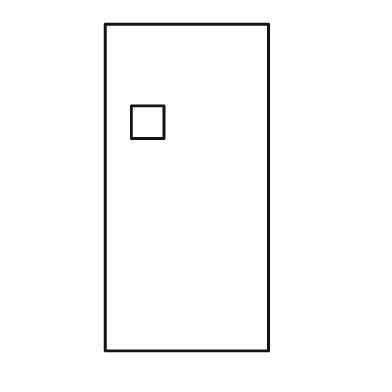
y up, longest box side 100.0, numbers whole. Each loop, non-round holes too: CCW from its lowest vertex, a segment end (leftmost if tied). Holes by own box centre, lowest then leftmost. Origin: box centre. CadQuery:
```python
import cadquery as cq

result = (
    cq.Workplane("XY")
    .moveTo(-25.0, -50.0)
    .lineTo(25.0, -50.0)
    .lineTo(25.0, 50.0)
    .lineTo(-25.0, 50.0)
    .close()
    .moveTo(-17.0, 15.0)
    .lineTo(-7.0, 15.0)
    .lineTo(-7.0, 25.0)
    .lineTo(-17.0, 25.0)
    .close()
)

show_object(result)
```